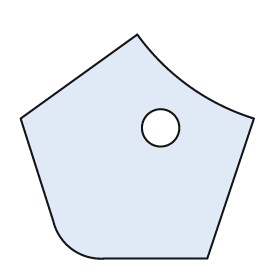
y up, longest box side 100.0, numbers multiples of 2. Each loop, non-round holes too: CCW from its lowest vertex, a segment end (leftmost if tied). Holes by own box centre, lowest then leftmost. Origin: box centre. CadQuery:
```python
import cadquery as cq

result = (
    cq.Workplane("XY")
    .moveTo(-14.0, -48.0)
    .lineTo(30.0, -48.0)
    .lineTo(50.0, 12.0)
    .threePointArc((22.0, 26.0), (0.0, 48.0))
    .lineTo(-50.0, 12.0)
    .lineTo(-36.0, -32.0)
    .threePointArc((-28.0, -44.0), (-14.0, -48.0))
    .close()
    .moveTo(10.0, 8.0)
    .circle(8.0)
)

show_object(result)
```